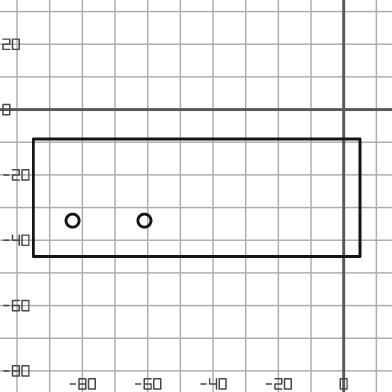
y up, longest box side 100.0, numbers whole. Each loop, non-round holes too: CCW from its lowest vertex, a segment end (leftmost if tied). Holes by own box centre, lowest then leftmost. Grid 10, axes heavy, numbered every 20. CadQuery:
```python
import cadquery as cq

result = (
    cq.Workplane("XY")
    .moveTo(-95.0, -45.0)
    .lineTo(5.0, -45.0)
    .lineTo(5.0, -9.0)
    .lineTo(-95.0, -9.0)
    .close()
    .moveTo(-83.0, -34.0)
    .circle(2.0)
    .moveTo(-61.0, -34.0)
    .circle(2.0)
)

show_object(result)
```